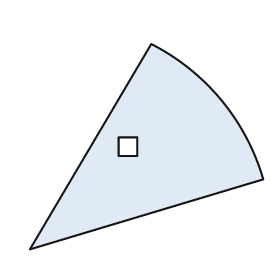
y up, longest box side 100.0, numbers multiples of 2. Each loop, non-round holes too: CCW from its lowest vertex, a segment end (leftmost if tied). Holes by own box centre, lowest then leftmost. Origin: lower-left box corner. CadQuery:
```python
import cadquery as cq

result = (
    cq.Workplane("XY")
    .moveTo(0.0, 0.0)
    .lineTo(100.0, 30.0)
    .threePointArc((82.0, 64.0), (52.0, 88.0))
    .close()
    .moveTo(38.0, 40.0)
    .lineTo(46.0, 40.0)
    .lineTo(46.0, 48.0)
    .lineTo(38.0, 48.0)
    .close()
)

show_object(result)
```